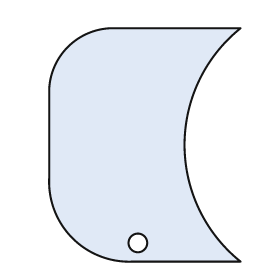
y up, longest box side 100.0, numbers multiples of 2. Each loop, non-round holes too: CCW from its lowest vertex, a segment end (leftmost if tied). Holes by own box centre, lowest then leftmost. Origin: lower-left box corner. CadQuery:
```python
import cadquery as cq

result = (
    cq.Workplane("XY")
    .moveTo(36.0, 0.0)
    .lineTo(82.0, 0.0)
    .threePointArc((58.0, 50.0), (82.0, 100.0))
    .lineTo(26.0, 100.0)
    .threePointArc((8.0, 92.0), (0.0, 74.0))
    .lineTo(0.0, 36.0)
    .threePointArc((10.0, 10.0), (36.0, 0.0))
    .close()
    .moveTo(38.0, 8.0)
    .circle(4.0)
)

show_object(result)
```